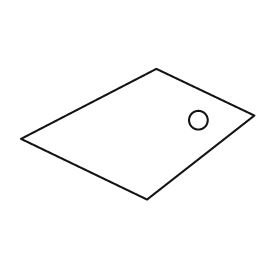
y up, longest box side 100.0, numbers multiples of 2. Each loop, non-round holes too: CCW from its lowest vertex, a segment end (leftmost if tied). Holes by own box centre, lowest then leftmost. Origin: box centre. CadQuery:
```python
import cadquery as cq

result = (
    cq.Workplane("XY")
    .moveTo(4.0, -28.0)
    .lineTo(50.0, 8.0)
    .lineTo(8.0, 28.0)
    .lineTo(-50.0, -2.0)
    .close()
    .moveTo(26.0, 6.0)
    .circle(4.0)
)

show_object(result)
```